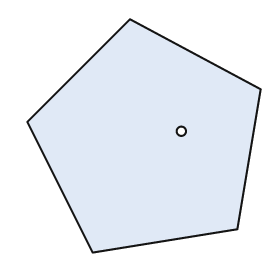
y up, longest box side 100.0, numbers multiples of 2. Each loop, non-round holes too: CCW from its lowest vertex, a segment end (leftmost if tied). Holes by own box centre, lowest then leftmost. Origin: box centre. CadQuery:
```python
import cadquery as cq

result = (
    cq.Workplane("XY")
    .moveTo(-22.0, -50.0)
    .lineTo(40.0, -40.0)
    .lineTo(50.0, 20.0)
    .lineTo(-6.0, 50.0)
    .lineTo(-50.0, 6.0)
    .close()
    .moveTo(16.0, 2.0)
    .circle(2.0)
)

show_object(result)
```